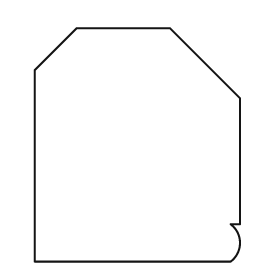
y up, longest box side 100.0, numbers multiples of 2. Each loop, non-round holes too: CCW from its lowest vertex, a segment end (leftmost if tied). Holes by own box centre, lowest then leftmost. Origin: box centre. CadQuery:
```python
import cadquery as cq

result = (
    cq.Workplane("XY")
    .moveTo(-44.0, -50.0)
    .lineTo(40.0, -50.0)
    .threePointArc((44.0, -42.0), (40.0, -34.0))
    .lineTo(44.0, -34.0)
    .lineTo(44.0, 20.0)
    .lineTo(14.0, 50.0)
    .lineTo(-26.0, 50.0)
    .lineTo(-44.0, 32.0)
    .close()
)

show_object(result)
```